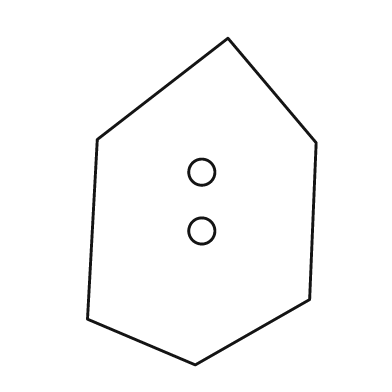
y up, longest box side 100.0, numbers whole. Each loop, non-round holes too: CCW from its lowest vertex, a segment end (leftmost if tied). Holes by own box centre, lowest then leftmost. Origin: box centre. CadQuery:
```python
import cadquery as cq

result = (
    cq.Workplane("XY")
    .moveTo(-2.0, -50.0)
    .lineTo(33.0, -30.0)
    .lineTo(35.0, 18.0)
    .lineTo(8.0, 50.0)
    .lineTo(-32.0, 19.0)
    .lineTo(-35.0, -36.0)
    .close()
    .moveTo(0.0, -9.0)
    .circle(4.0)
    .moveTo(0.0, 9.0)
    .circle(4.0)
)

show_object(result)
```